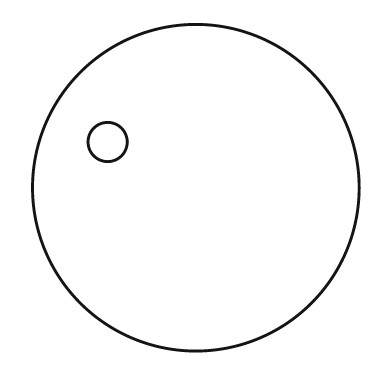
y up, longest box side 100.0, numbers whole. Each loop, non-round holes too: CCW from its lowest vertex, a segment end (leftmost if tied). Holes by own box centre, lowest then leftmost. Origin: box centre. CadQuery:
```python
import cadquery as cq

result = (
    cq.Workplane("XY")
    .moveTo(0.0, 0.0)
    .circle(50.0)
    .moveTo(-27.0, 14.0)
    .circle(6.0)
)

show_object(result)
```